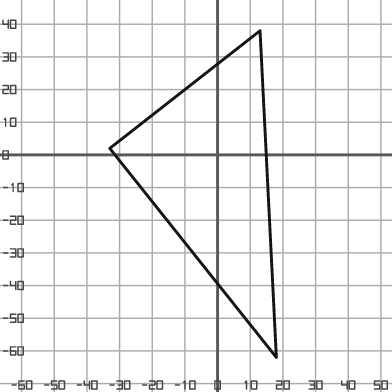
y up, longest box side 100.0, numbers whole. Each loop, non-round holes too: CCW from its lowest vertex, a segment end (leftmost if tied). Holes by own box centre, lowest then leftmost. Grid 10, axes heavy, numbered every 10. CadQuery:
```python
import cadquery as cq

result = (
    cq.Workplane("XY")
    .moveTo(18.0, -62.0)
    .lineTo(13.0, 38.0)
    .lineTo(-33.0, 2.0)
    .close()
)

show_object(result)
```